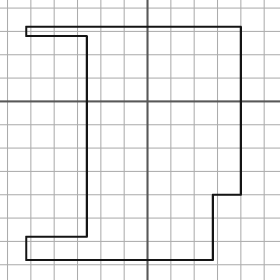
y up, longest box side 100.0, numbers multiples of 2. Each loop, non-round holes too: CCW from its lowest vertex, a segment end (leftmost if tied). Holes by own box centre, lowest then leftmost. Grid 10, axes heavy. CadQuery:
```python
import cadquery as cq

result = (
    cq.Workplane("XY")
    .moveTo(-52.0, -68.0)
    .lineTo(28.0, -68.0)
    .lineTo(28.0, -40.0)
    .lineTo(40.0, -40.0)
    .lineTo(40.0, 32.0)
    .lineTo(-52.0, 32.0)
    .lineTo(-52.0, 28.0)
    .lineTo(-26.0, 28.0)
    .lineTo(-26.0, -58.0)
    .lineTo(-52.0, -58.0)
    .close()
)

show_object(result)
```